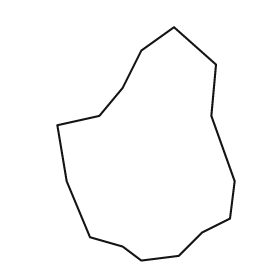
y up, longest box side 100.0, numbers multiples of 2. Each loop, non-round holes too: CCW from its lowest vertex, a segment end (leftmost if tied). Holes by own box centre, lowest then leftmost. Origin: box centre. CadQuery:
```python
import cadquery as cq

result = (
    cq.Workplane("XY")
    .moveTo(-2.0, -50.0)
    .lineTo(14.0, -48.0)
    .lineTo(24.0, -38.0)
    .lineTo(36.0, -32.0)
    .lineTo(38.0, -16.0)
    .lineTo(28.0, 12.0)
    .lineTo(30.0, 34.0)
    .lineTo(12.0, 50.0)
    .lineTo(-2.0, 40.0)
    .lineTo(-10.0, 24.0)
    .lineTo(-20.0, 12.0)
    .lineTo(-38.0, 8.0)
    .lineTo(-34.0, -16.0)
    .lineTo(-24.0, -40.0)
    .lineTo(-10.0, -44.0)
    .close()
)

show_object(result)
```